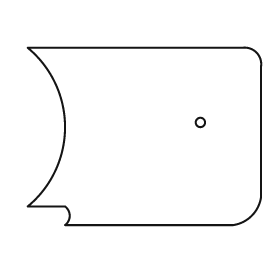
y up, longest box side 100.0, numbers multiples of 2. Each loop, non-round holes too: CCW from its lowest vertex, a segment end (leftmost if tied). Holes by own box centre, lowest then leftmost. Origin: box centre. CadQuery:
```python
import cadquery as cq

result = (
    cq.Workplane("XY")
    .moveTo(-34.0, -38.0)
    .lineTo(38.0, -38.0)
    .threePointArc((46.0, -34.0), (50.0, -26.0))
    .lineTo(50.0, 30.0)
    .threePointArc((48.0, 36.0), (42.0, 38.0))
    .lineTo(-50.0, 38.0)
    .threePointArc((-34.0, 4.0), (-50.0, -30.0))
    .lineTo(-34.0, -30.0)
    .threePointArc((-32.0, -34.0), (-34.0, -38.0))
    .close()
    .moveTo(24.0, 6.0)
    .circle(2.0)
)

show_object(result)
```